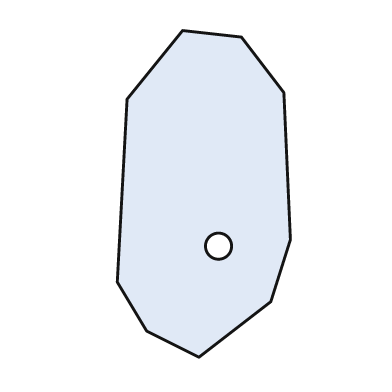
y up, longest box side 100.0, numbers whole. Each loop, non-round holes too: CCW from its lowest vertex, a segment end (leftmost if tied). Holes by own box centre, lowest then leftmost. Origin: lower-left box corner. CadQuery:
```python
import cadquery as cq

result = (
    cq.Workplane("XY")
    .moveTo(25.0, 0.0)
    .lineTo(47.0, 17.0)
    .lineTo(53.0, 36.0)
    .lineTo(51.0, 81.0)
    .lineTo(38.0, 98.0)
    .lineTo(20.0, 100.0)
    .lineTo(3.0, 79.0)
    .lineTo(0.0, 23.0)
    .lineTo(9.0, 8.0)
    .close()
    .moveTo(31.0, 34.0)
    .circle(4.0)
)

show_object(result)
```